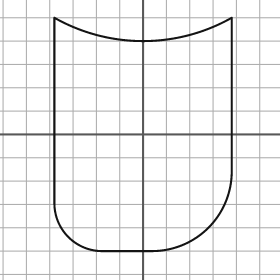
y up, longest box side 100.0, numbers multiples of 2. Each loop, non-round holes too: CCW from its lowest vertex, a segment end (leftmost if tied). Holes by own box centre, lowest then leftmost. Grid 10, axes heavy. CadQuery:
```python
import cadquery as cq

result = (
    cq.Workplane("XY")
    .moveTo(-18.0, -50.0)
    .lineTo(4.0, -50.0)
    .threePointArc((28.0, -40.0), (38.0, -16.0))
    .lineTo(38.0, 50.0)
    .threePointArc((0.0, 40.0), (-38.0, 50.0))
    .lineTo(-38.0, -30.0)
    .threePointArc((-32.0, -44.0), (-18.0, -50.0))
    .close()
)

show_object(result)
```